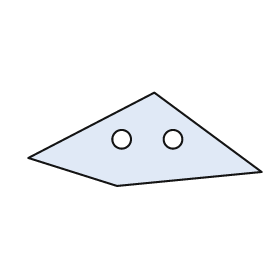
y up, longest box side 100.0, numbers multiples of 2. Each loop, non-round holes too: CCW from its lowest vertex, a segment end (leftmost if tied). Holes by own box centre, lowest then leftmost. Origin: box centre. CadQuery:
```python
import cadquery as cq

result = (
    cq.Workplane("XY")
    .moveTo(-12.0, -20.0)
    .lineTo(50.0, -14.0)
    .lineTo(4.0, 20.0)
    .lineTo(-50.0, -8.0)
    .close()
    .moveTo(-10.0, 0.0)
    .circle(4.0)
    .moveTo(12.0, 0.0)
    .circle(4.0)
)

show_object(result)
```